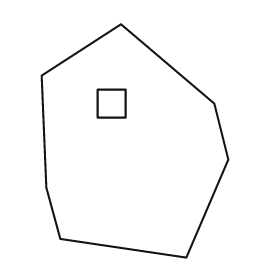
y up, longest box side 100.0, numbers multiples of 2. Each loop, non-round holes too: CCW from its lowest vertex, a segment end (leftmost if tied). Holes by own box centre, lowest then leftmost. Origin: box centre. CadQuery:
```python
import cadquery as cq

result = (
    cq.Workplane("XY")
    .moveTo(22.0, -50.0)
    .lineTo(40.0, -8.0)
    .lineTo(34.0, 16.0)
    .lineTo(-6.0, 50.0)
    .lineTo(-40.0, 28.0)
    .lineTo(-38.0, -20.0)
    .lineTo(-32.0, -42.0)
    .close()
    .moveTo(-16.0, 10.0)
    .lineTo(-4.0, 10.0)
    .lineTo(-4.0, 22.0)
    .lineTo(-16.0, 22.0)
    .close()
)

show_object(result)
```